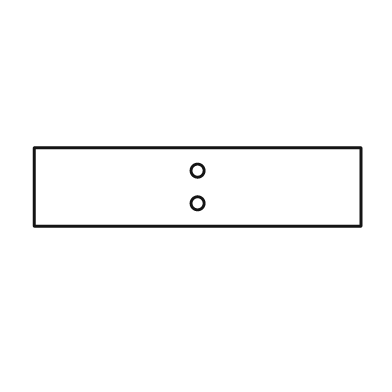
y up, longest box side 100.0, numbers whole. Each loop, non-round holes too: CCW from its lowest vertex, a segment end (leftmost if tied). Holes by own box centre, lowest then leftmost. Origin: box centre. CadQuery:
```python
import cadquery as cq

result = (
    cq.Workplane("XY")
    .moveTo(-50.0, -12.0)
    .lineTo(50.0, -12.0)
    .lineTo(50.0, 12.0)
    .lineTo(-50.0, 12.0)
    .close()
    .moveTo(0.0, -5.0)
    .circle(2.0)
    .moveTo(0.0, 5.0)
    .circle(2.0)
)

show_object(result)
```